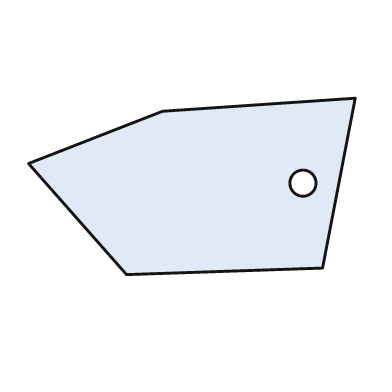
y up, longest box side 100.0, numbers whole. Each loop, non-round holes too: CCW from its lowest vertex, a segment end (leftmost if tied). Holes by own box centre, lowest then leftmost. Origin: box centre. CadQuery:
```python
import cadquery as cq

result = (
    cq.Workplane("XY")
    .moveTo(-20.0, -27.0)
    .lineTo(40.0, -25.0)
    .lineTo(50.0, 27.0)
    .lineTo(-9.0, 23.0)
    .lineTo(-50.0, 7.0)
    .close()
    .moveTo(34.0, 1.0)
    .circle(4.0)
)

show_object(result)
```